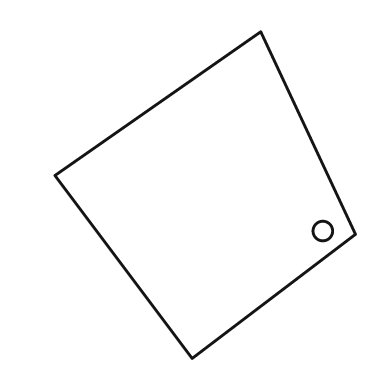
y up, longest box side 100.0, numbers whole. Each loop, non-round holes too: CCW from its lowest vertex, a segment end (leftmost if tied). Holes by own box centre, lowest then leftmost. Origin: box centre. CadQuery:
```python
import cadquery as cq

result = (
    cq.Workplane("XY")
    .moveTo(-4.0, -50.0)
    .lineTo(46.0, -12.0)
    .lineTo(17.0, 50.0)
    .lineTo(-46.0, 6.0)
    .close()
    .moveTo(36.0, -11.0)
    .circle(3.0)
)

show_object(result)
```